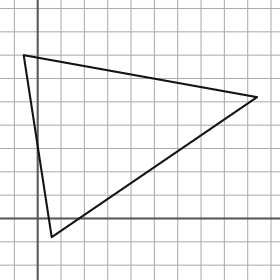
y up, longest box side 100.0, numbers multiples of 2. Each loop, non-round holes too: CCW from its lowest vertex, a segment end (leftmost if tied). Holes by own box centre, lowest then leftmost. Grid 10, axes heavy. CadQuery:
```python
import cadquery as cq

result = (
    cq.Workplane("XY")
    .moveTo(6.0, -8.0)
    .lineTo(94.0, 52.0)
    .lineTo(-6.0, 70.0)
    .close()
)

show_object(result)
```